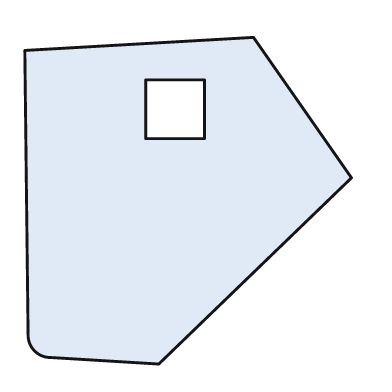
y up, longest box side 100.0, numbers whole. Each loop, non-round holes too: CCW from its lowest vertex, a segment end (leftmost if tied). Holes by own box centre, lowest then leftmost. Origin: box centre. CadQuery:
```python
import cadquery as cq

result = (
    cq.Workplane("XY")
    .moveTo(-9.0, -50.0)
    .lineTo(50.0, 7.0)
    .lineTo(20.0, 50.0)
    .lineTo(-50.0, 46.0)
    .lineTo(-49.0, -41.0)
    .threePointArc((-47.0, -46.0), (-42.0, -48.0))
    .close()
    .moveTo(-13.0, 19.0)
    .lineTo(5.0, 19.0)
    .lineTo(5.0, 37.0)
    .lineTo(-13.0, 37.0)
    .close()
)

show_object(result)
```